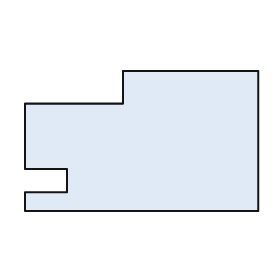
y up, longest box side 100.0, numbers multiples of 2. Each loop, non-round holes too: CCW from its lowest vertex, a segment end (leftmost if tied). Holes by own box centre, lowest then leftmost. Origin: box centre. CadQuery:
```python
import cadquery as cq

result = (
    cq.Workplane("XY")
    .moveTo(-50.0, -30.0)
    .lineTo(50.0, -30.0)
    .lineTo(50.0, 30.0)
    .lineTo(-8.0, 30.0)
    .lineTo(-8.0, 16.0)
    .lineTo(-50.0, 16.0)
    .lineTo(-50.0, -12.0)
    .lineTo(-32.0, -12.0)
    .lineTo(-32.0, -22.0)
    .lineTo(-50.0, -22.0)
    .close()
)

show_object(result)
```